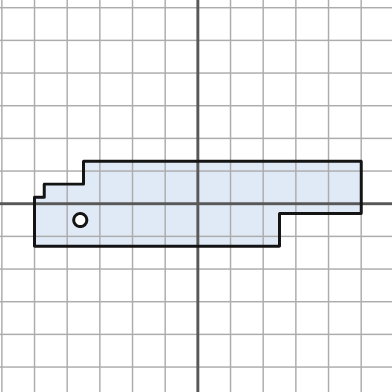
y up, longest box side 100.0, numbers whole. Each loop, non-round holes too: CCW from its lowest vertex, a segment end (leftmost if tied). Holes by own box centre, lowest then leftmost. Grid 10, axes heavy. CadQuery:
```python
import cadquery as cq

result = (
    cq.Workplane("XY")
    .moveTo(-50.0, -13.0)
    .lineTo(25.0, -13.0)
    .lineTo(25.0, -3.0)
    .lineTo(50.0, -3.0)
    .lineTo(50.0, 13.0)
    .lineTo(-35.0, 13.0)
    .lineTo(-35.0, 6.0)
    .lineTo(-47.0, 6.0)
    .lineTo(-47.0, 2.0)
    .lineTo(-50.0, 2.0)
    .close()
    .moveTo(-36.0, -5.0)
    .circle(2.0)
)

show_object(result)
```